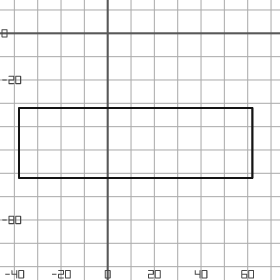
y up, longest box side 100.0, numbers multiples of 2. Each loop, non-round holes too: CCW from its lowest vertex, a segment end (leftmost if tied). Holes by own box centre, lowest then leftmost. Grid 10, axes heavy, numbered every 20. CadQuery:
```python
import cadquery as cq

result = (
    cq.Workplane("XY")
    .moveTo(-38.0, -62.0)
    .lineTo(62.0, -62.0)
    .lineTo(62.0, -32.0)
    .lineTo(-38.0, -32.0)
    .close()
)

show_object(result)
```